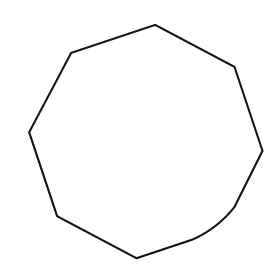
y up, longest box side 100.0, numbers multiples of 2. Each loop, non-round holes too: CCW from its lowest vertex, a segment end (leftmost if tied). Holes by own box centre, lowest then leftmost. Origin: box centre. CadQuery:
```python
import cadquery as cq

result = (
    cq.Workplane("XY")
    .moveTo(-4.0, -50.0)
    .lineTo(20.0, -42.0)
    .threePointArc((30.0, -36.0), (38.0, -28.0))
    .lineTo(50.0, -4.0)
    .lineTo(38.0, 32.0)
    .lineTo(4.0, 50.0)
    .lineTo(-32.0, 38.0)
    .lineTo(-50.0, 4.0)
    .lineTo(-38.0, -32.0)
    .close()
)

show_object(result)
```